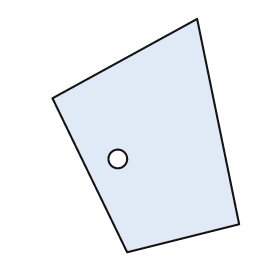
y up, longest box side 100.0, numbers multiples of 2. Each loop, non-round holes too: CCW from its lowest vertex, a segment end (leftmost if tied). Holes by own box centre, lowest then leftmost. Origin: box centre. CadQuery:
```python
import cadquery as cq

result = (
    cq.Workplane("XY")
    .moveTo(-8.0, -50.0)
    .lineTo(40.0, -38.0)
    .lineTo(22.0, 50.0)
    .lineTo(-40.0, 16.0)
    .close()
    .moveTo(-12.0, -10.0)
    .circle(4.0)
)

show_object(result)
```